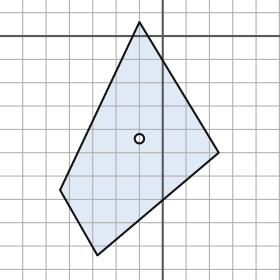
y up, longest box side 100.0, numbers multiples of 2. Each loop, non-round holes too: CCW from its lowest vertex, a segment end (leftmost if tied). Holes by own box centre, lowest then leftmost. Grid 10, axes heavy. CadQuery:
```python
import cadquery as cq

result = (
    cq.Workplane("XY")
    .moveTo(-28.0, -94.0)
    .lineTo(24.0, -50.0)
    .lineTo(-10.0, 6.0)
    .lineTo(-44.0, -66.0)
    .close()
    .moveTo(-10.0, -44.0)
    .circle(2.0)
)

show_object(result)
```